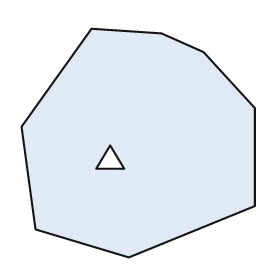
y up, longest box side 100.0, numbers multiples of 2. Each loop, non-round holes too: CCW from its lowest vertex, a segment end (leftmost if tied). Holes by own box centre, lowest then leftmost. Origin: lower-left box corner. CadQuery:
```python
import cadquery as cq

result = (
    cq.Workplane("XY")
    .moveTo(46.0, 0.0)
    .lineTo(100.0, 22.0)
    .lineTo(100.0, 64.0)
    .lineTo(78.0, 88.0)
    .lineTo(60.0, 96.0)
    .lineTo(30.0, 98.0)
    .lineTo(0.0, 56.0)
    .lineTo(6.0, 12.0)
    .close()
    .moveTo(32.0, 38.0)
    .lineTo(44.0, 38.0)
    .lineTo(38.0, 48.0)
    .close()
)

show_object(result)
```